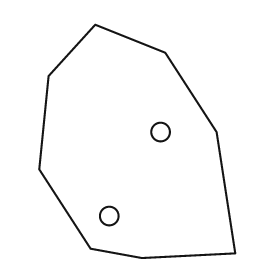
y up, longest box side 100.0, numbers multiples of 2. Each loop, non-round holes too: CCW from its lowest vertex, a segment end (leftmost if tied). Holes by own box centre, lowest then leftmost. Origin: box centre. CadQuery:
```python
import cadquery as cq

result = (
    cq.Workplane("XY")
    .moveTo(2.0, -50.0)
    .lineTo(42.0, -48.0)
    .lineTo(34.0, 4.0)
    .lineTo(12.0, 38.0)
    .lineTo(-18.0, 50.0)
    .lineTo(-38.0, 28.0)
    .lineTo(-42.0, -12.0)
    .lineTo(-20.0, -46.0)
    .close()
    .moveTo(-12.0, -32.0)
    .circle(4.0)
    .moveTo(10.0, 4.0)
    .circle(4.0)
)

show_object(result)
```